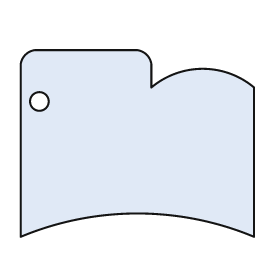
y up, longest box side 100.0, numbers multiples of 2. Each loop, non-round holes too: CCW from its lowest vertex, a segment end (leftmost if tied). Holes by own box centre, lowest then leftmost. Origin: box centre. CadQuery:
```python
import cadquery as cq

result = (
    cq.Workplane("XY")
    .moveTo(-50.0, -40.0)
    .threePointArc((0.0, -30.0), (50.0, -40.0))
    .lineTo(50.0, 24.0)
    .threePointArc((28.0, 32.0), (6.0, 24.0))
    .lineTo(6.0, 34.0)
    .threePointArc((4.0, 38.0), (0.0, 40.0))
    .lineTo(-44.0, 40.0)
    .threePointArc((-48.0, 38.0), (-50.0, 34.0))
    .close()
    .moveTo(-42.0, 18.0)
    .circle(4.0)
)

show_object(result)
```